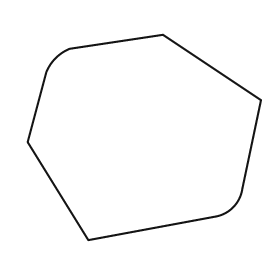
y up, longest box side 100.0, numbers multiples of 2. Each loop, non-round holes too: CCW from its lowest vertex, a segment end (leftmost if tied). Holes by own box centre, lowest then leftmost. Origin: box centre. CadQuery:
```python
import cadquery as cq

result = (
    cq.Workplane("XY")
    .moveTo(-24.0, -44.0)
    .lineTo(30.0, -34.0)
    .threePointArc((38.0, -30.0), (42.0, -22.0))
    .lineTo(50.0, 16.0)
    .lineTo(8.0, 44.0)
    .lineTo(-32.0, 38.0)
    .threePointArc((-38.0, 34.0), (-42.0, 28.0))
    .lineTo(-50.0, -2.0)
    .close()
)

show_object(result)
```